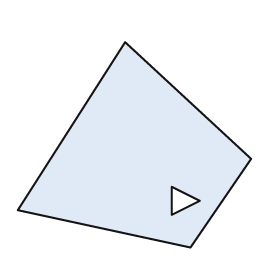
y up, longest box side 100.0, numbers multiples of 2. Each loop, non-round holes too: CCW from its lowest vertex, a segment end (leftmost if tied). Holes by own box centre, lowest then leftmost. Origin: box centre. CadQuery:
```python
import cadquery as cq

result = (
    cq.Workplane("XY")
    .moveTo(24.0, -44.0)
    .lineTo(50.0, -6.0)
    .lineTo(-4.0, 44.0)
    .lineTo(-50.0, -28.0)
    .close()
    .moveTo(16.0, -30.0)
    .lineTo(28.0, -24.0)
    .lineTo(16.0, -18.0)
    .close()
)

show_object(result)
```